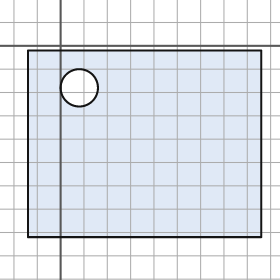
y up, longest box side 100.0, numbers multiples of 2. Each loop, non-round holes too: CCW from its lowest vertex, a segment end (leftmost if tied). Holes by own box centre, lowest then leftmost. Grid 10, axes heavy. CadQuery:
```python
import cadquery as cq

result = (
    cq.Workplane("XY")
    .moveTo(-14.0, -82.0)
    .lineTo(86.0, -82.0)
    .lineTo(86.0, -2.0)
    .lineTo(-14.0, -2.0)
    .close()
    .moveTo(8.0, -18.0)
    .circle(8.0)
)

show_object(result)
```